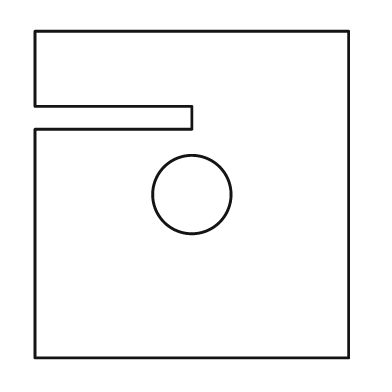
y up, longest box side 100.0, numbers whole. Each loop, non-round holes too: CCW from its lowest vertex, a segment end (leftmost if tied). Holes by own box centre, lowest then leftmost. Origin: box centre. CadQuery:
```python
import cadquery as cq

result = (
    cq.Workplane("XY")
    .moveTo(-48.0, -50.0)
    .lineTo(48.0, -50.0)
    .lineTo(48.0, 50.0)
    .lineTo(-48.0, 50.0)
    .lineTo(-48.0, 27.0)
    .lineTo(0.0, 27.0)
    .lineTo(0.0, 20.0)
    .lineTo(-48.0, 20.0)
    .close()
    .moveTo(0.0, 0.0)
    .circle(12.0)
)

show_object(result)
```